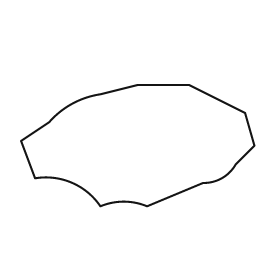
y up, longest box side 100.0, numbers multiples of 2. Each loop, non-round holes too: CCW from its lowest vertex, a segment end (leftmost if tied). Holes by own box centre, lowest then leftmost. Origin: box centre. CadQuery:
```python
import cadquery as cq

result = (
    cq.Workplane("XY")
    .moveTo(-16.0, -26.0)
    .threePointArc((-6.0, -24.0), (4.0, -26.0))
    .lineTo(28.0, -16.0)
    .threePointArc((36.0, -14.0), (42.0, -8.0))
    .lineTo(50.0, 0.0)
    .lineTo(46.0, 14.0)
    .lineTo(22.0, 26.0)
    .lineTo(0.0, 26.0)
    .lineTo(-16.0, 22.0)
    .threePointArc((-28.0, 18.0), (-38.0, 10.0))
    .lineTo(-50.0, 2.0)
    .lineTo(-44.0, -14.0)
    .threePointArc((-28.0, -16.0), (-16.0, -26.0))
    .close()
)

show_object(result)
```